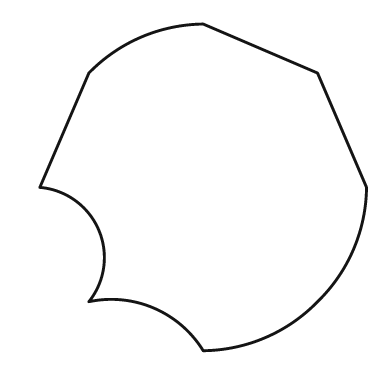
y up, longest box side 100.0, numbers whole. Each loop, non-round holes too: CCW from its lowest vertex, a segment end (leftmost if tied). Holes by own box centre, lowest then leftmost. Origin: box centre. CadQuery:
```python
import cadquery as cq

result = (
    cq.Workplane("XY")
    .moveTo(0.0, -50.0)
    .threePointArc((19.0, -46.0), (35.0, -35.0))
    .threePointArc((46.0, -19.0), (50.0, 0.0))
    .lineTo(35.0, 35.0)
    .lineTo(0.0, 50.0)
    .threePointArc((-19.0, 46.0), (-35.0, 35.0))
    .lineTo(-50.0, 0.0)
    .threePointArc((-32.0, -13.0), (-35.0, -35.0))
    .threePointArc((-15.0, -37.0), (0.0, -50.0))
    .close()
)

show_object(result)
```